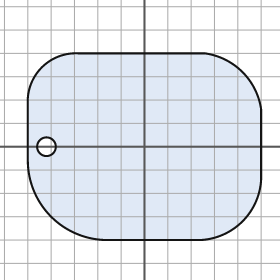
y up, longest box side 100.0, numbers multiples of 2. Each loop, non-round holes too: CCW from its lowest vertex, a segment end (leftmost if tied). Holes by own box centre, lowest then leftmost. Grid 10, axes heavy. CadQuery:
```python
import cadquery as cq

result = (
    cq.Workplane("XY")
    .moveTo(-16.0, -40.0)
    .lineTo(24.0, -40.0)
    .threePointArc((42.0, -32.0), (50.0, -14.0))
    .lineTo(50.0, 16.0)
    .threePointArc((42.0, 32.0), (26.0, 40.0))
    .lineTo(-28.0, 40.0)
    .threePointArc((-44.0, 34.0), (-50.0, 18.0))
    .lineTo(-50.0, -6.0)
    .threePointArc((-40.0, -30.0), (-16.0, -40.0))
    .close()
    .moveTo(-42.0, 0.0)
    .circle(4.0)
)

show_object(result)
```